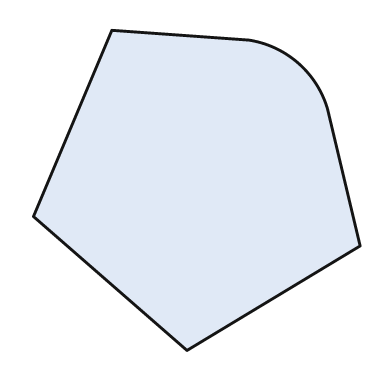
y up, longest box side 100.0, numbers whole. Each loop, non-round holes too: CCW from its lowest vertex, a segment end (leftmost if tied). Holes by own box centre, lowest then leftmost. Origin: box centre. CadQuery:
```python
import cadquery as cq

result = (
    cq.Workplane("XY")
    .moveTo(-3.0, -49.0)
    .lineTo(50.0, -17.0)
    .lineTo(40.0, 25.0)
    .threePointArc((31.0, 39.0), (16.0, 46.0))
    .lineTo(-26.0, 49.0)
    .lineTo(-50.0, -8.0)
    .close()
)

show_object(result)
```